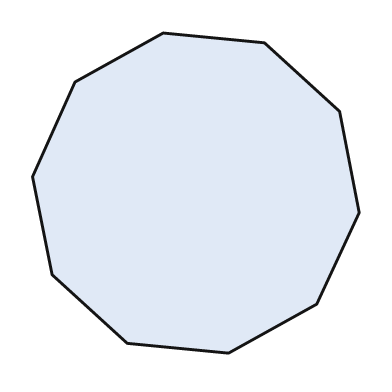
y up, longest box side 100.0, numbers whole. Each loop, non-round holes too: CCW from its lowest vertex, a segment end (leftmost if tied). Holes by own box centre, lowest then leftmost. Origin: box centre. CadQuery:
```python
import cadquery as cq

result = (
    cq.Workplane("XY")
    .moveTo(10.0, -49.0)
    .lineTo(37.0, -34.0)
    .lineTo(50.0, -6.0)
    .lineTo(44.0, 25.0)
    .lineTo(21.0, 46.0)
    .lineTo(-10.0, 49.0)
    .lineTo(-37.0, 34.0)
    .lineTo(-50.0, 5.0)
    .lineTo(-44.0, -25.0)
    .lineTo(-21.0, -46.0)
    .close()
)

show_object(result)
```